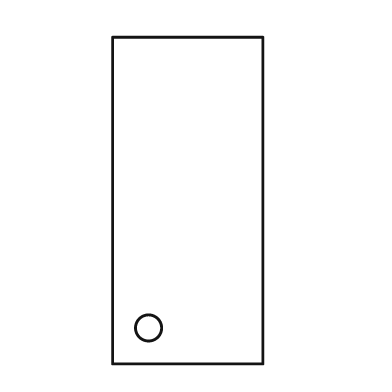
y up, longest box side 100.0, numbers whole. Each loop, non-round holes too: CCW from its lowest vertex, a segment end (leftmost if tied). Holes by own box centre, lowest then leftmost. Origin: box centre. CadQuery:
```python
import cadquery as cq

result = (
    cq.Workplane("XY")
    .moveTo(-23.0, -50.0)
    .lineTo(23.0, -50.0)
    .lineTo(23.0, 50.0)
    .lineTo(-23.0, 50.0)
    .close()
    .moveTo(-12.0, -39.0)
    .circle(4.0)
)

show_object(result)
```